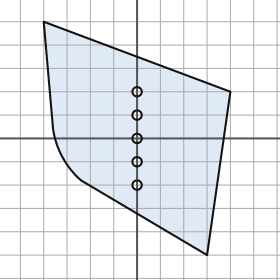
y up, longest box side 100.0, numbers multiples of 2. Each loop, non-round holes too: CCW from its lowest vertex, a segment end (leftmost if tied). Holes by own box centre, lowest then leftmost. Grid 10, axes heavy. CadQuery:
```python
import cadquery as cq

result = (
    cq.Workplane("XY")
    .moveTo(30.0, -50.0)
    .lineTo(40.0, 20.0)
    .lineTo(-40.0, 50.0)
    .lineTo(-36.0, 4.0)
    .threePointArc((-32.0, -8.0), (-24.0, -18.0))
    .close()
    .moveTo(0.0, -20.0)
    .circle(2.0)
    .moveTo(0.0, -10.0)
    .circle(2.0)
    .moveTo(0.0, 0.0)
    .circle(2.0)
    .moveTo(0.0, 10.0)
    .circle(2.0)
    .moveTo(0.0, 20.0)
    .circle(2.0)
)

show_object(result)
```